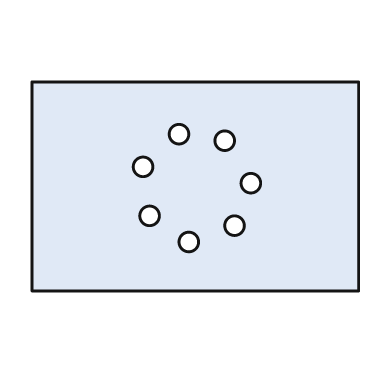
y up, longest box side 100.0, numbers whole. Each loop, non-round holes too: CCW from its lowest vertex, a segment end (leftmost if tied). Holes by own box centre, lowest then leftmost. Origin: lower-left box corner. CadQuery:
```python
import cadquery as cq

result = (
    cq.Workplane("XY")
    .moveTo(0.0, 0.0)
    .lineTo(100.0, 0.0)
    .lineTo(100.0, 64.0)
    .lineTo(0.0, 64.0)
    .close()
    .moveTo(48.0, 15.0)
    .circle(3.0)
    .moveTo(62.0, 20.0)
    .circle(3.0)
    .moveTo(36.0, 23.0)
    .circle(3.0)
    .moveTo(67.0, 33.0)
    .circle(3.0)
    .moveTo(34.0, 38.0)
    .circle(3.0)
    .moveTo(59.0, 46.0)
    .circle(3.0)
    .moveTo(45.0, 48.0)
    .circle(3.0)
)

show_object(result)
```